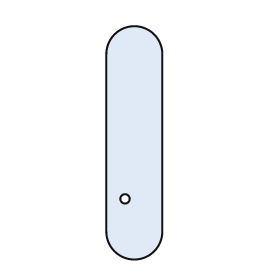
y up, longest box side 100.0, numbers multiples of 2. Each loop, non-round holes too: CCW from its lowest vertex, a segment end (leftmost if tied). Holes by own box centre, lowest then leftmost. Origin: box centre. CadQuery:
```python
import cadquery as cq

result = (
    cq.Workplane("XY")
    .moveTo(-12.0, -38.0)
    .threePointArc((0.0, -50.0), (12.0, -38.0))
    .lineTo(12.0, 38.0)
    .threePointArc((0.0, 50.0), (-12.0, 38.0))
    .close()
    .moveTo(-4.0, -24.0)
    .circle(2.0)
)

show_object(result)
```